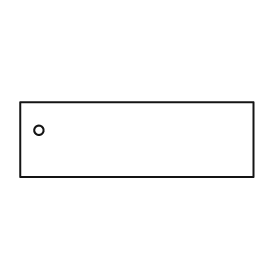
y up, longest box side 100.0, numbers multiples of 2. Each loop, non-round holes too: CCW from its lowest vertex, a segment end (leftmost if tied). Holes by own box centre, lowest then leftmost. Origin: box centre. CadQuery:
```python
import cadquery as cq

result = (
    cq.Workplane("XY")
    .moveTo(-50.0, -16.0)
    .lineTo(50.0, -16.0)
    .lineTo(50.0, 16.0)
    .lineTo(-50.0, 16.0)
    .close()
    .moveTo(-42.0, 4.0)
    .circle(2.0)
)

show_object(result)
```